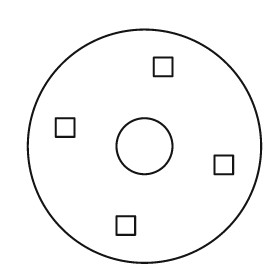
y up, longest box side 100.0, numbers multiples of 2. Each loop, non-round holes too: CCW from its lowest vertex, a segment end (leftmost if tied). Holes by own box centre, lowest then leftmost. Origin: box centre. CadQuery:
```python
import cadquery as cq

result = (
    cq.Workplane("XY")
    .moveTo(0.0, 0.0)
    .circle(50.0)
    .moveTo(-12.0, -38.0)
    .lineTo(-4.0, -38.0)
    .lineTo(-4.0, -30.0)
    .lineTo(-12.0, -30.0)
    .close()
    .moveTo(30.0, -12.0)
    .lineTo(38.0, -12.0)
    .lineTo(38.0, -4.0)
    .lineTo(30.0, -4.0)
    .close()
    .moveTo(0.0, 0.0)
    .circle(12.0)
    .moveTo(-38.0, 4.0)
    .lineTo(-30.0, 4.0)
    .lineTo(-30.0, 12.0)
    .lineTo(-38.0, 12.0)
    .close()
    .moveTo(4.0, 30.0)
    .lineTo(12.0, 30.0)
    .lineTo(12.0, 38.0)
    .lineTo(4.0, 38.0)
    .close()
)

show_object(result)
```